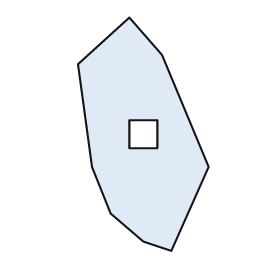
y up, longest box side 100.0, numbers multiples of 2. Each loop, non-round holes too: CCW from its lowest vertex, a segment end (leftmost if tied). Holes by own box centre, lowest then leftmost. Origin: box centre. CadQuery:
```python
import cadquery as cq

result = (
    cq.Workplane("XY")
    .moveTo(12.0, -50.0)
    .lineTo(28.0, -14.0)
    .lineTo(8.0, 34.0)
    .lineTo(-6.0, 50.0)
    .lineTo(-28.0, 30.0)
    .lineTo(-22.0, -14.0)
    .lineTo(-14.0, -34.0)
    .lineTo(0.0, -46.0)
    .close()
    .moveTo(-6.0, -6.0)
    .lineTo(6.0, -6.0)
    .lineTo(6.0, 6.0)
    .lineTo(-6.0, 6.0)
    .close()
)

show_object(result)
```